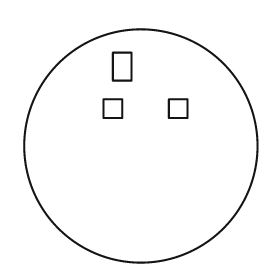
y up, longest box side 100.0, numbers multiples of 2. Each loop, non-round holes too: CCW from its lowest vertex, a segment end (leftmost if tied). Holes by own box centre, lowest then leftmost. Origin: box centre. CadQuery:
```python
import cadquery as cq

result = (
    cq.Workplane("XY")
    .moveTo(0.0, 0.0)
    .circle(50.0)
    .moveTo(-16.0, 12.0)
    .lineTo(-8.0, 12.0)
    .lineTo(-8.0, 20.0)
    .lineTo(-16.0, 20.0)
    .close()
    .moveTo(12.0, 12.0)
    .lineTo(20.0, 12.0)
    .lineTo(20.0, 20.0)
    .lineTo(12.0, 20.0)
    .close()
    .moveTo(-12.0, 28.0)
    .lineTo(-4.0, 28.0)
    .lineTo(-4.0, 40.0)
    .lineTo(-12.0, 40.0)
    .close()
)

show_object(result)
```